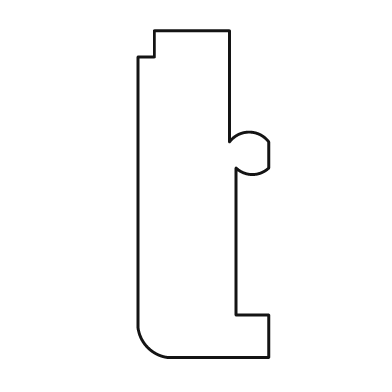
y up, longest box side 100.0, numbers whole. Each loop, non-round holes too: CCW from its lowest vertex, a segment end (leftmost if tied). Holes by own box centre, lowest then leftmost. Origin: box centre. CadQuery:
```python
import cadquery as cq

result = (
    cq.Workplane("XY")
    .moveTo(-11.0, -50.0)
    .lineTo(20.0, -50.0)
    .lineTo(20.0, -37.0)
    .lineTo(10.0, -37.0)
    .lineTo(10.0, 8.0)
    .threePointArc((15.0, 6.0), (20.0, 8.0))
    .lineTo(20.0, 16.0)
    .threePointArc((14.0, 19.0), (8.0, 16.0))
    .lineTo(8.0, 50.0)
    .lineTo(-15.0, 50.0)
    .lineTo(-15.0, 42.0)
    .lineTo(-20.0, 42.0)
    .lineTo(-20.0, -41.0)
    .threePointArc((-17.0, -47.0), (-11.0, -50.0))
    .close()
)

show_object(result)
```